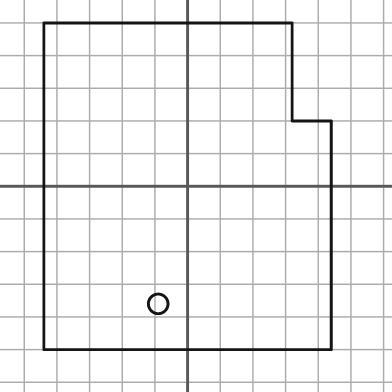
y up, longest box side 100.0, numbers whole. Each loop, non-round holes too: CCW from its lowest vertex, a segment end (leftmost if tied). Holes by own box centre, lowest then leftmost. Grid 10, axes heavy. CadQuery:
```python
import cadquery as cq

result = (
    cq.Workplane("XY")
    .moveTo(-44.0, -50.0)
    .lineTo(44.0, -50.0)
    .lineTo(44.0, 20.0)
    .lineTo(32.0, 20.0)
    .lineTo(32.0, 50.0)
    .lineTo(-44.0, 50.0)
    .close()
    .moveTo(-9.0, -36.0)
    .circle(3.0)
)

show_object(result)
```